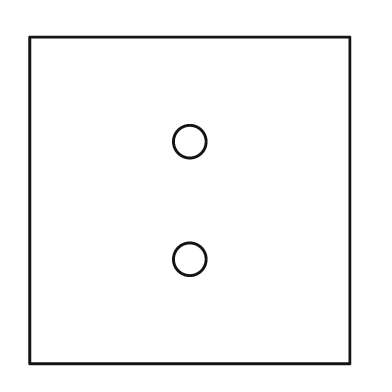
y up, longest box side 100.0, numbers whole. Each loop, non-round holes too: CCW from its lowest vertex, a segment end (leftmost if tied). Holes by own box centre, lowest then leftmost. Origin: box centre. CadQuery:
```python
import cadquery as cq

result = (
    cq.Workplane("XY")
    .moveTo(-49.0, -50.0)
    .lineTo(49.0, -50.0)
    .lineTo(49.0, 50.0)
    .lineTo(-49.0, 50.0)
    .close()
    .moveTo(0.0, -18.0)
    .circle(5.0)
    .moveTo(0.0, 18.0)
    .circle(5.0)
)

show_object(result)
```